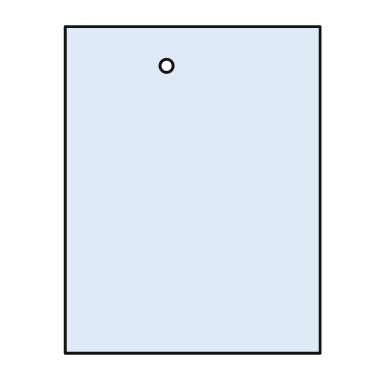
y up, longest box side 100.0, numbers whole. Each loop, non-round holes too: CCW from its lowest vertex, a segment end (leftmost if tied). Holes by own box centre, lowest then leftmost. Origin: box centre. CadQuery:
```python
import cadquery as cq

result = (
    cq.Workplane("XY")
    .moveTo(-39.0, -50.0)
    .lineTo(39.0, -50.0)
    .lineTo(39.0, 50.0)
    .lineTo(-39.0, 50.0)
    .close()
    .moveTo(-8.0, 38.0)
    .circle(2.0)
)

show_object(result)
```